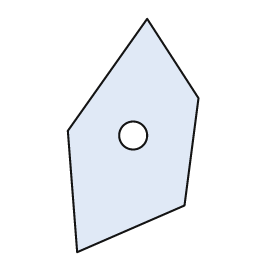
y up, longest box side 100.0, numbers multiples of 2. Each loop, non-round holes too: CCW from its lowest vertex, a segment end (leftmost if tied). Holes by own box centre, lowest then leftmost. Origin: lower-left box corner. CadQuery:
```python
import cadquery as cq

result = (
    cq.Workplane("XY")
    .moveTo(4.0, 0.0)
    .lineTo(50.0, 20.0)
    .lineTo(56.0, 66.0)
    .lineTo(34.0, 100.0)
    .lineTo(0.0, 52.0)
    .close()
    .moveTo(28.0, 50.0)
    .circle(6.0)
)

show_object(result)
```